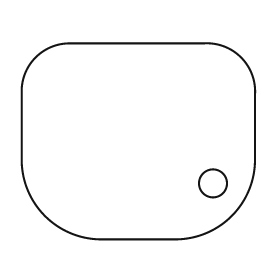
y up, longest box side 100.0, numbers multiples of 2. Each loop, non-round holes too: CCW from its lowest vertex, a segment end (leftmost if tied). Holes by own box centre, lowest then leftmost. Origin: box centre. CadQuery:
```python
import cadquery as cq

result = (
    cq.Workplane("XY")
    .moveTo(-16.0, -42.0)
    .lineTo(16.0, -42.0)
    .threePointArc((40.0, -32.0), (50.0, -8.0))
    .lineTo(50.0, 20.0)
    .threePointArc((44.0, 36.0), (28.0, 42.0))
    .lineTo(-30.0, 42.0)
    .threePointArc((-44.0, 36.0), (-50.0, 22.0))
    .lineTo(-50.0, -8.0)
    .threePointArc((-40.0, -32.0), (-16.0, -42.0))
    .close()
    .moveTo(32.0, -18.0)
    .circle(6.0)
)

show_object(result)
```